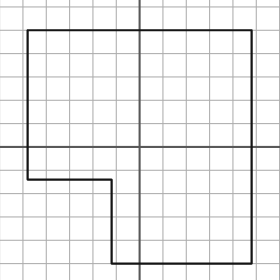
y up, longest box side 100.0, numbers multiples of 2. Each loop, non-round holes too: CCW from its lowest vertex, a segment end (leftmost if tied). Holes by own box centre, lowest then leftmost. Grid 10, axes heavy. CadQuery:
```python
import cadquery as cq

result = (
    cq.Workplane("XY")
    .moveTo(-12.0, -50.0)
    .lineTo(48.0, -50.0)
    .lineTo(48.0, 50.0)
    .lineTo(-48.0, 50.0)
    .lineTo(-48.0, -14.0)
    .lineTo(-12.0, -14.0)
    .close()
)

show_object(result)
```